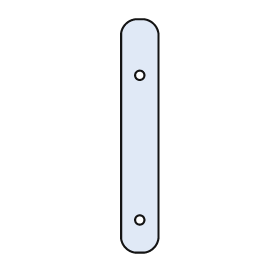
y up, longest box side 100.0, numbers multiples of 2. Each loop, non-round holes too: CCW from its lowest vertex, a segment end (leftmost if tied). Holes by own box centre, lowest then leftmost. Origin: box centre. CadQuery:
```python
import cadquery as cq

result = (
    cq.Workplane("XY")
    .moveTo(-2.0, -50.0)
    .lineTo(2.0, -50.0)
    .threePointArc((6.0, -48.0), (8.0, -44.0))
    .lineTo(8.0, 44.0)
    .threePointArc((6.0, 48.0), (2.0, 50.0))
    .lineTo(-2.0, 50.0)
    .threePointArc((-6.0, 48.0), (-8.0, 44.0))
    .lineTo(-8.0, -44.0)
    .threePointArc((-6.0, -48.0), (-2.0, -50.0))
    .close()
    .moveTo(0.0, -36.0)
    .circle(2.0)
    .moveTo(0.0, 26.0)
    .circle(2.0)
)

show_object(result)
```